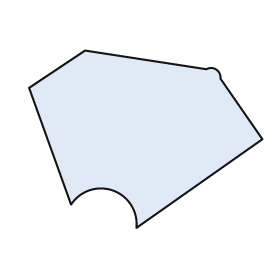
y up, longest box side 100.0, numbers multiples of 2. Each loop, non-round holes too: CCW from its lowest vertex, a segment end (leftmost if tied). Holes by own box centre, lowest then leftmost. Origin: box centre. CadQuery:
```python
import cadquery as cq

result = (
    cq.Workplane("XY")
    .moveTo(-4.0, -38.0)
    .lineTo(50.0, 0.0)
    .lineTo(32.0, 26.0)
    .threePointArc((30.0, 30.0), (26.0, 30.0))
    .lineTo(-26.0, 38.0)
    .lineTo(-50.0, 22.0)
    .lineTo(-32.0, -28.0)
    .threePointArc((-14.0, -22.0), (-4.0, -38.0))
    .close()
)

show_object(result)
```